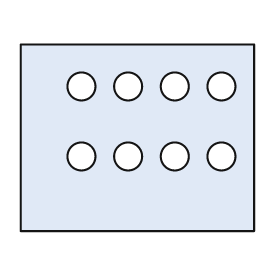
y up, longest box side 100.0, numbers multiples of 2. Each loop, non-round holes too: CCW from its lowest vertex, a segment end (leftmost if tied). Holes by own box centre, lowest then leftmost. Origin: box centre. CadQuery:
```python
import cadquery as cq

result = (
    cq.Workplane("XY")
    .moveTo(-50.0, -40.0)
    .lineTo(50.0, -40.0)
    .lineTo(50.0, 40.0)
    .lineTo(-50.0, 40.0)
    .close()
    .moveTo(-24.0, -8.0)
    .circle(6.0)
    .moveTo(-4.0, -8.0)
    .circle(6.0)
    .moveTo(16.0, -8.0)
    .circle(6.0)
    .moveTo(36.0, -8.0)
    .circle(6.0)
    .moveTo(-24.0, 22.0)
    .circle(6.0)
    .moveTo(-4.0, 22.0)
    .circle(6.0)
    .moveTo(16.0, 22.0)
    .circle(6.0)
    .moveTo(36.0, 22.0)
    .circle(6.0)
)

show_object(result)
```